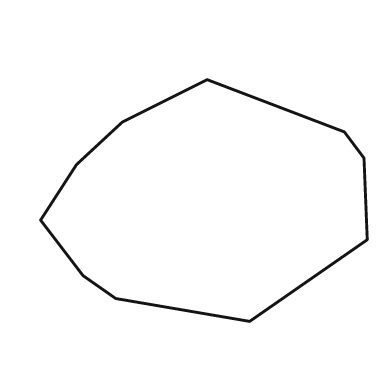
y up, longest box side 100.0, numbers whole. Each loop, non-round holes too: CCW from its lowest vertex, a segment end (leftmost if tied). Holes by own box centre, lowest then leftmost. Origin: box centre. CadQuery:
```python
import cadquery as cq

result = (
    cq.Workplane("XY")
    .moveTo(14.0, -37.0)
    .lineTo(50.0, -12.0)
    .lineTo(49.0, 13.0)
    .lineTo(43.0, 21.0)
    .lineTo(1.0, 37.0)
    .lineTo(-25.0, 24.0)
    .lineTo(-39.0, 11.0)
    .lineTo(-50.0, -6.0)
    .lineTo(-37.0, -23.0)
    .lineTo(-27.0, -30.0)
    .close()
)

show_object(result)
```